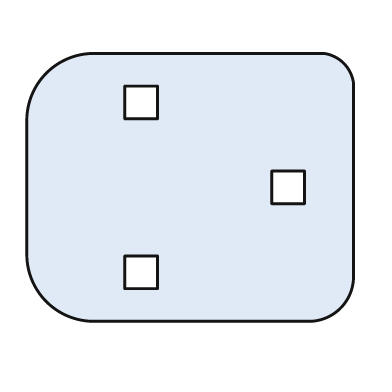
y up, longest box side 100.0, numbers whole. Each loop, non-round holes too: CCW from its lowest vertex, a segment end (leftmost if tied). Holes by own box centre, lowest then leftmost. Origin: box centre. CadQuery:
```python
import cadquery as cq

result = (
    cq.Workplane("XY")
    .moveTo(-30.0, -41.0)
    .lineTo(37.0, -41.0)
    .threePointArc((46.0, -37.0), (50.0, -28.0))
    .lineTo(50.0, 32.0)
    .threePointArc((47.0, 38.0), (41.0, 41.0))
    .lineTo(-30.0, 41.0)
    .threePointArc((-44.0, 35.0), (-50.0, 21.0))
    .lineTo(-50.0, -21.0)
    .threePointArc((-44.0, -35.0), (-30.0, -41.0))
    .close()
    .moveTo(-20.0, -31.0)
    .lineTo(-10.0, -31.0)
    .lineTo(-10.0, -21.0)
    .lineTo(-20.0, -21.0)
    .close()
    .moveTo(25.0, -5.0)
    .lineTo(35.0, -5.0)
    .lineTo(35.0, 5.0)
    .lineTo(25.0, 5.0)
    .close()
    .moveTo(-20.0, 21.0)
    .lineTo(-10.0, 21.0)
    .lineTo(-10.0, 31.0)
    .lineTo(-20.0, 31.0)
    .close()
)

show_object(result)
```